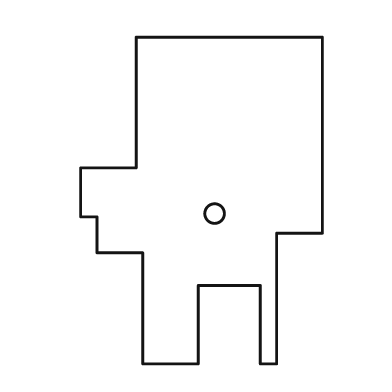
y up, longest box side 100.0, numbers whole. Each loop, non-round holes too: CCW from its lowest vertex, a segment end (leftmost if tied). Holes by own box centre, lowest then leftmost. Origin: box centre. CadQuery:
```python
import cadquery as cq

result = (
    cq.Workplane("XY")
    .moveTo(-18.0, -50.0)
    .lineTo(-1.0, -50.0)
    .lineTo(-1.0, -26.0)
    .lineTo(18.0, -26.0)
    .lineTo(18.0, -50.0)
    .lineTo(23.0, -50.0)
    .lineTo(23.0, -10.0)
    .lineTo(37.0, -10.0)
    .lineTo(37.0, 50.0)
    .lineTo(-20.0, 50.0)
    .lineTo(-20.0, 10.0)
    .lineTo(-37.0, 10.0)
    .lineTo(-37.0, -5.0)
    .lineTo(-32.0, -5.0)
    .lineTo(-32.0, -16.0)
    .lineTo(-18.0, -16.0)
    .close()
    .moveTo(4.0, -4.0)
    .circle(3.0)
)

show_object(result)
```